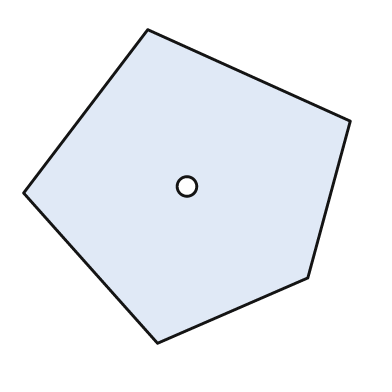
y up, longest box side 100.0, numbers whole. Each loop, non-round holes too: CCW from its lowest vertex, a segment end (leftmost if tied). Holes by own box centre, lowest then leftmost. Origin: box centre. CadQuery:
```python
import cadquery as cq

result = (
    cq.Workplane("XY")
    .moveTo(-9.0, -48.0)
    .lineTo(37.0, -28.0)
    .lineTo(50.0, 20.0)
    .lineTo(-12.0, 48.0)
    .lineTo(-50.0, -2.0)
    .close()
    .moveTo(0.0, 0.0)
    .circle(3.0)
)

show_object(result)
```